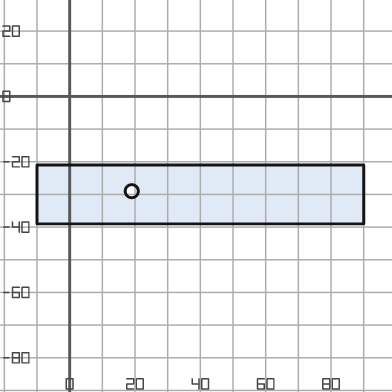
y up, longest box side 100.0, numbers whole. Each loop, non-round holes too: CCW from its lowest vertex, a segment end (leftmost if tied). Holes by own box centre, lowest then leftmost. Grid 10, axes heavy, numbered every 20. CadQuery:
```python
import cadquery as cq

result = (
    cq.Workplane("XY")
    .moveTo(-10.0, -39.0)
    .lineTo(90.0, -39.0)
    .lineTo(90.0, -21.0)
    .lineTo(-10.0, -21.0)
    .close()
    .moveTo(19.0, -29.0)
    .circle(2.0)
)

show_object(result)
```